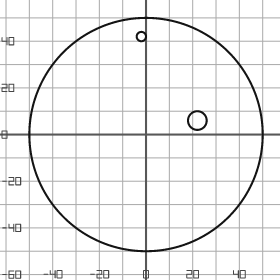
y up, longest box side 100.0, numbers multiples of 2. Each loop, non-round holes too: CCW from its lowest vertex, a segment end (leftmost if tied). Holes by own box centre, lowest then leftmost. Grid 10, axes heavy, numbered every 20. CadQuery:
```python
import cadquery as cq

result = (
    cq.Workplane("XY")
    .moveTo(0.0, 0.0)
    .circle(50.0)
    .moveTo(22.0, 6.0)
    .circle(4.0)
    .moveTo(-2.0, 42.0)
    .circle(2.0)
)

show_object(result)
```